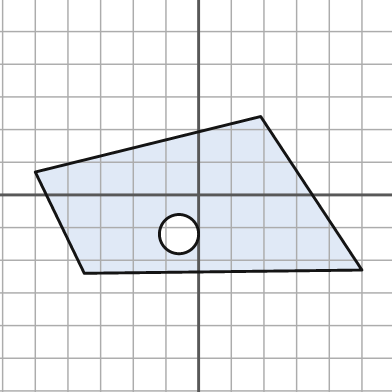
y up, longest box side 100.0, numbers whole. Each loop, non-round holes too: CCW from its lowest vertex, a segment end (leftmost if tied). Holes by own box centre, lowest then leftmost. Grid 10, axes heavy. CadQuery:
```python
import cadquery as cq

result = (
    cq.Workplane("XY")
    .moveTo(-35.0, -24.0)
    .lineTo(50.0, -23.0)
    .lineTo(19.0, 24.0)
    .lineTo(-50.0, 7.0)
    .close()
    .moveTo(-6.0, -12.0)
    .circle(6.0)
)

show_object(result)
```